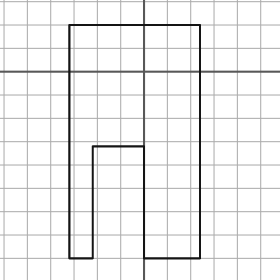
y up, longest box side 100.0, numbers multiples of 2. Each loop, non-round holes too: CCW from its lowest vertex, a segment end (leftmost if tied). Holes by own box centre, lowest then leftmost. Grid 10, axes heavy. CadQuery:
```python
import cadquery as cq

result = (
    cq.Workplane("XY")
    .moveTo(-32.0, -80.0)
    .lineTo(-22.0, -80.0)
    .lineTo(-22.0, -32.0)
    .lineTo(0.0, -32.0)
    .lineTo(0.0, -80.0)
    .lineTo(24.0, -80.0)
    .lineTo(24.0, 20.0)
    .lineTo(-32.0, 20.0)
    .close()
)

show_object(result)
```